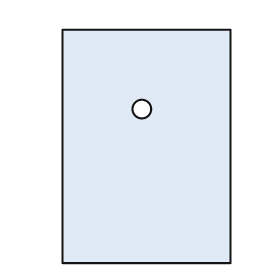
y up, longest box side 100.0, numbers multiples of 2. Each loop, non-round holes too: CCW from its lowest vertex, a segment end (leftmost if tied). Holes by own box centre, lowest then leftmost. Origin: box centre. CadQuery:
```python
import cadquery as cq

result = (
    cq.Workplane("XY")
    .moveTo(-36.0, -50.0)
    .lineTo(36.0, -50.0)
    .lineTo(36.0, 50.0)
    .lineTo(-36.0, 50.0)
    .close()
    .moveTo(-2.0, 16.0)
    .circle(4.0)
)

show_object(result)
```